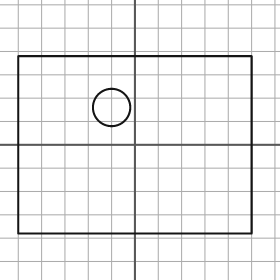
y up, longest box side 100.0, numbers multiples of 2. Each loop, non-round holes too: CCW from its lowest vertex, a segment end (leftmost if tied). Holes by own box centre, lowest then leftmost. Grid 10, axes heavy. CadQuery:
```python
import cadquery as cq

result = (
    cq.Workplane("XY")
    .moveTo(-50.0, -38.0)
    .lineTo(50.0, -38.0)
    .lineTo(50.0, 38.0)
    .lineTo(-50.0, 38.0)
    .close()
    .moveTo(-10.0, 16.0)
    .circle(8.0)
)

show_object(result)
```